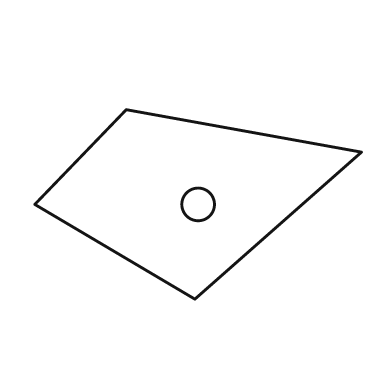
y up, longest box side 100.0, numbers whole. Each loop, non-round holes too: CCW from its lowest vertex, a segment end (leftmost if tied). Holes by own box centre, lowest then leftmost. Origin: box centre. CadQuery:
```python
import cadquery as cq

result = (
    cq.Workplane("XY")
    .moveTo(-1.0, -29.0)
    .lineTo(50.0, 16.0)
    .lineTo(-22.0, 29.0)
    .lineTo(-50.0, 0.0)
    .close()
    .moveTo(0.0, 0.0)
    .circle(5.0)
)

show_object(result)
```